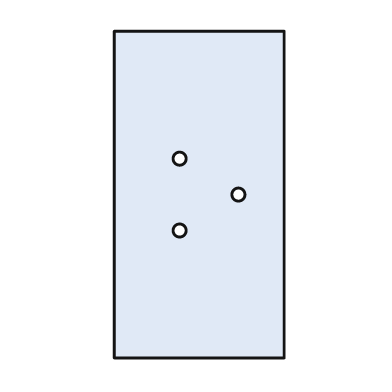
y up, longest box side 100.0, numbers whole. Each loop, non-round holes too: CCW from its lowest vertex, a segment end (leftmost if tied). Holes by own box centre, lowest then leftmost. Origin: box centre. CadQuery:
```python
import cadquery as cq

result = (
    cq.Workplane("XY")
    .moveTo(-26.0, -50.0)
    .lineTo(26.0, -50.0)
    .lineTo(26.0, 50.0)
    .lineTo(-26.0, 50.0)
    .close()
    .moveTo(-6.0, -11.0)
    .circle(2.0)
    .moveTo(12.0, 0.0)
    .circle(2.0)
    .moveTo(-6.0, 11.0)
    .circle(2.0)
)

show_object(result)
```